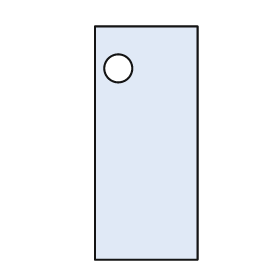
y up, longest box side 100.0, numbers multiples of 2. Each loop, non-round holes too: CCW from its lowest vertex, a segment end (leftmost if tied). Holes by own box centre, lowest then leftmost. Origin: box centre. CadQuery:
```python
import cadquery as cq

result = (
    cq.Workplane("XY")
    .moveTo(-22.0, -50.0)
    .lineTo(22.0, -50.0)
    .lineTo(22.0, 50.0)
    .lineTo(-22.0, 50.0)
    .close()
    .moveTo(-12.0, 32.0)
    .circle(6.0)
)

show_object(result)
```